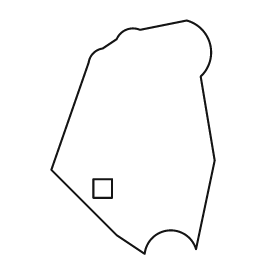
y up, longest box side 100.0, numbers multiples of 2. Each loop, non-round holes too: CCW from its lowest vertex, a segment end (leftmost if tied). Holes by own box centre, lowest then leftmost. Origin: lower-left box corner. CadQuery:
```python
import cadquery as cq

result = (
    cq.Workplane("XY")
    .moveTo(40.0, 0.0)
    .threePointArc((50.0, 10.0), (62.0, 2.0))
    .lineTo(70.0, 40.0)
    .lineTo(64.0, 76.0)
    .threePointArc((68.0, 90.0), (58.0, 100.0))
    .lineTo(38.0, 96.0)
    .threePointArc((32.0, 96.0), (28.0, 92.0))
    .lineTo(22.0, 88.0)
    .threePointArc((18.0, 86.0), (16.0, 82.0))
    .lineTo(0.0, 36.0)
    .lineTo(28.0, 8.0)
    .close()
    .moveTo(18.0, 24.0)
    .lineTo(26.0, 24.0)
    .lineTo(26.0, 32.0)
    .lineTo(18.0, 32.0)
    .close()
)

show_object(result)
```